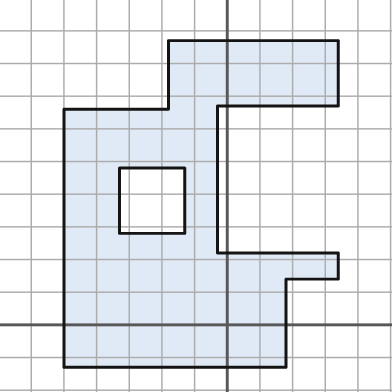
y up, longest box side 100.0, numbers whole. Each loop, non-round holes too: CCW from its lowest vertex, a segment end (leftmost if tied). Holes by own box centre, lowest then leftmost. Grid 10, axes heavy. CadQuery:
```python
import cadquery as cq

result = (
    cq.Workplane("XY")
    .moveTo(-50.0, -13.0)
    .lineTo(18.0, -13.0)
    .lineTo(18.0, 14.0)
    .lineTo(34.0, 14.0)
    .lineTo(34.0, 22.0)
    .lineTo(-3.0, 22.0)
    .lineTo(-3.0, 67.0)
    .lineTo(34.0, 67.0)
    .lineTo(34.0, 87.0)
    .lineTo(-18.0, 87.0)
    .lineTo(-18.0, 66.0)
    .lineTo(-50.0, 66.0)
    .close()
    .moveTo(-33.0, 28.0)
    .lineTo(-13.0, 28.0)
    .lineTo(-13.0, 48.0)
    .lineTo(-33.0, 48.0)
    .close()
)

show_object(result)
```